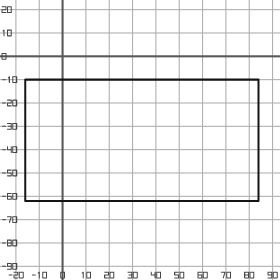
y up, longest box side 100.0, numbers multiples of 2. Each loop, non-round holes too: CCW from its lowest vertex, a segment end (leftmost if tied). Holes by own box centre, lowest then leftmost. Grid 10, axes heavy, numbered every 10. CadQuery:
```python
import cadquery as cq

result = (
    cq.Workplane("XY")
    .moveTo(-16.0, -62.0)
    .lineTo(84.0, -62.0)
    .lineTo(84.0, -10.0)
    .lineTo(-16.0, -10.0)
    .close()
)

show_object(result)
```